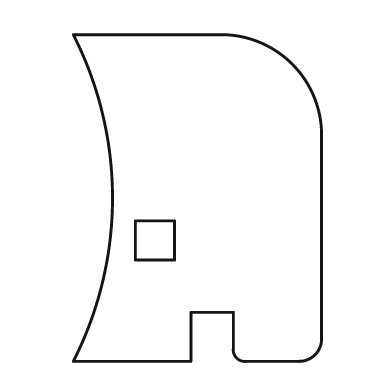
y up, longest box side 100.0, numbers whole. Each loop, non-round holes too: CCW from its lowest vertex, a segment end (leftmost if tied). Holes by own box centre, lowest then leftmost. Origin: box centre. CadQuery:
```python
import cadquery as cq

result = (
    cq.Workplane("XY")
    .moveTo(-38.0, -50.0)
    .lineTo(-2.0, -50.0)
    .lineTo(-2.0, -35.0)
    .lineTo(11.0, -35.0)
    .lineTo(11.0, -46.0)
    .threePointArc((12.0, -49.0), (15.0, -50.0))
    .lineTo(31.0, -50.0)
    .threePointArc((36.0, -48.0), (38.0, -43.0))
    .lineTo(38.0, 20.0)
    .threePointArc((29.0, 41.0), (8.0, 50.0))
    .lineTo(-38.0, 50.0)
    .threePointArc((-26.0, 0.0), (-38.0, -50.0))
    .close()
    .moveTo(-19.0, -19.0)
    .lineTo(-7.0, -19.0)
    .lineTo(-7.0, -7.0)
    .lineTo(-19.0, -7.0)
    .close()
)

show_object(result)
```